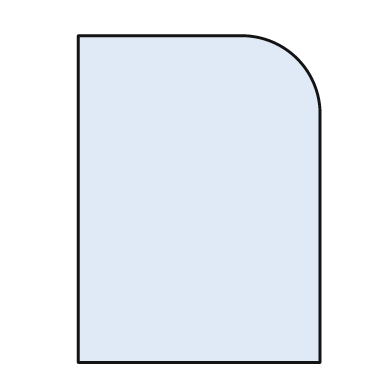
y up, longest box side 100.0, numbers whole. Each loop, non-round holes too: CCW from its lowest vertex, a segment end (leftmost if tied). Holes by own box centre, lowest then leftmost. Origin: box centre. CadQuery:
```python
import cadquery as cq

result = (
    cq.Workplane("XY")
    .moveTo(-37.0, -50.0)
    .lineTo(37.0, -50.0)
    .lineTo(37.0, 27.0)
    .threePointArc((30.0, 43.0), (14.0, 50.0))
    .lineTo(-37.0, 50.0)
    .close()
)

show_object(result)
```